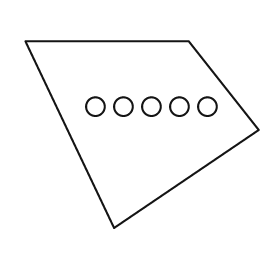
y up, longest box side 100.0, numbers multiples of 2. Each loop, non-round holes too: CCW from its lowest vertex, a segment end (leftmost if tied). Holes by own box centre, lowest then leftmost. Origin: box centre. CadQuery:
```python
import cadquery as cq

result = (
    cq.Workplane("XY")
    .moveTo(-12.0, -40.0)
    .lineTo(50.0, 2.0)
    .lineTo(20.0, 40.0)
    .lineTo(-50.0, 40.0)
    .close()
    .moveTo(-20.0, 12.0)
    .circle(4.0)
    .moveTo(-8.0, 12.0)
    .circle(4.0)
    .moveTo(4.0, 12.0)
    .circle(4.0)
    .moveTo(16.0, 12.0)
    .circle(4.0)
    .moveTo(28.0, 12.0)
    .circle(4.0)
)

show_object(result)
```